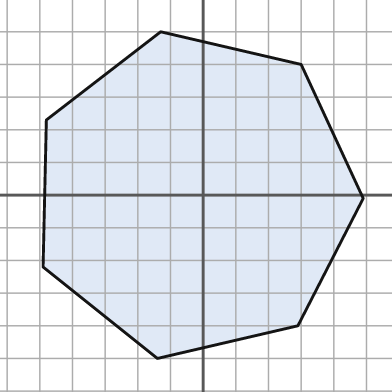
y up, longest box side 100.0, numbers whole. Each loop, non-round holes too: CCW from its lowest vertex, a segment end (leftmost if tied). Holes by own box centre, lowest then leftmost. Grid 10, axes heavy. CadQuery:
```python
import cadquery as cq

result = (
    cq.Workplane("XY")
    .moveTo(-14.0, -50.0)
    .lineTo(29.0, -40.0)
    .lineTo(49.0, -1.0)
    .lineTo(30.0, 40.0)
    .lineTo(-13.0, 50.0)
    .lineTo(-48.0, 23.0)
    .lineTo(-49.0, -22.0)
    .close()
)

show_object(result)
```